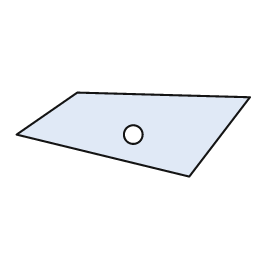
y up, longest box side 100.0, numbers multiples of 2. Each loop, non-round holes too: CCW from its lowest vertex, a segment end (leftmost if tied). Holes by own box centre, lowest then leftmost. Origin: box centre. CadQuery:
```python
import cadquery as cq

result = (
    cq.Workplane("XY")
    .moveTo(24.0, -18.0)
    .lineTo(50.0, 16.0)
    .lineTo(-24.0, 18.0)
    .lineTo(-50.0, 0.0)
    .close()
    .moveTo(0.0, 0.0)
    .circle(4.0)
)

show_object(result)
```